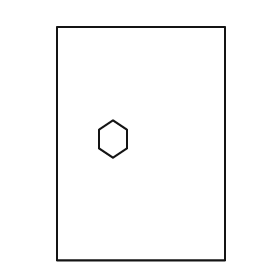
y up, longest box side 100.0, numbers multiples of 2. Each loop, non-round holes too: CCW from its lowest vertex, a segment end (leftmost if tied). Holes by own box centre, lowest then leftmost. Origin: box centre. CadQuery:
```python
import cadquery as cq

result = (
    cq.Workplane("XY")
    .moveTo(-36.0, -50.0)
    .lineTo(36.0, -50.0)
    .lineTo(36.0, 50.0)
    .lineTo(-36.0, 50.0)
    .close()
    .moveTo(-12.0, -6.0)
    .lineTo(-6.0, -2.0)
    .lineTo(-6.0, 6.0)
    .lineTo(-12.0, 10.0)
    .lineTo(-18.0, 6.0)
    .lineTo(-18.0, -2.0)
    .close()
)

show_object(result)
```